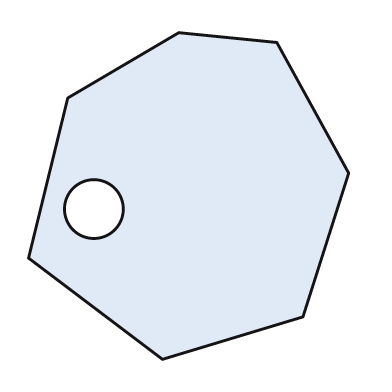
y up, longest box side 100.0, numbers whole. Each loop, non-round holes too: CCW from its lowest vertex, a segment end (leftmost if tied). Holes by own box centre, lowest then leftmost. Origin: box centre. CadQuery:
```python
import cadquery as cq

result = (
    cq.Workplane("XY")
    .moveTo(-8.0, -50.0)
    .lineTo(35.0, -37.0)
    .lineTo(49.0, 7.0)
    .lineTo(27.0, 47.0)
    .lineTo(-3.0, 50.0)
    .lineTo(-37.0, 30.0)
    .lineTo(-49.0, -19.0)
    .close()
    .moveTo(-29.0, -4.0)
    .circle(9.0)
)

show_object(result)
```